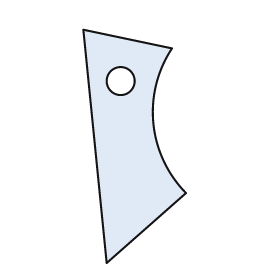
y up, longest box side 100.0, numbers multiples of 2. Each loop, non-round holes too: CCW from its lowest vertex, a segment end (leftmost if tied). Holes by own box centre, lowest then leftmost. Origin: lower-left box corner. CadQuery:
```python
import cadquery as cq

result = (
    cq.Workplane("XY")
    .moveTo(10.0, 0.0)
    .lineTo(44.0, 30.0)
    .threePointArc((30.0, 60.0), (38.0, 92.0))
    .lineTo(0.0, 100.0)
    .close()
    .moveTo(16.0, 78.0)
    .circle(6.0)
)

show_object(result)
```